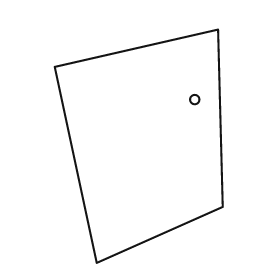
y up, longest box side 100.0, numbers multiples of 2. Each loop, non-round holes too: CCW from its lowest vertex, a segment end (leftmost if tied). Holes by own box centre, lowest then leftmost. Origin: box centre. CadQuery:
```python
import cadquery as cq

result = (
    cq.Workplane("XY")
    .moveTo(-18.0, -50.0)
    .lineTo(36.0, -26.0)
    .lineTo(34.0, 50.0)
    .lineTo(-36.0, 34.0)
    .close()
    .moveTo(24.0, 20.0)
    .circle(2.0)
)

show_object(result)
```